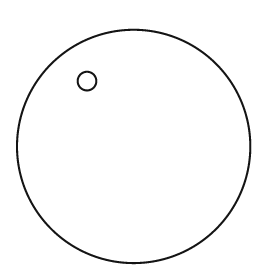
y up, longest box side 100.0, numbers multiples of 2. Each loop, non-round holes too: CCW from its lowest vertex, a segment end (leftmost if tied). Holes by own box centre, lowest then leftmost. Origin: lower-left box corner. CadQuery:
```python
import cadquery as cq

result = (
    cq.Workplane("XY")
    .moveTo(50.0, 50.0)
    .circle(50.0)
    .moveTo(30.0, 78.0)
    .circle(4.0)
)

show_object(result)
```